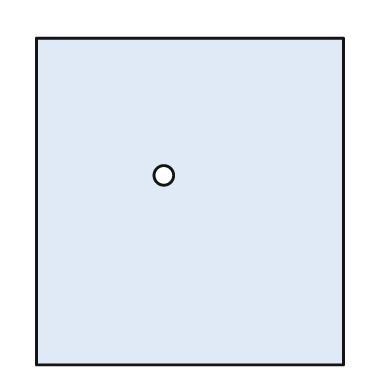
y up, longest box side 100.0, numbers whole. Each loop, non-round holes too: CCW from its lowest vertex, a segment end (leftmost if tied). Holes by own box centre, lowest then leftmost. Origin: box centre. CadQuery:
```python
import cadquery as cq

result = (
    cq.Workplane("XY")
    .moveTo(-47.0, -50.0)
    .lineTo(47.0, -50.0)
    .lineTo(47.0, 50.0)
    .lineTo(-47.0, 50.0)
    .close()
    .moveTo(-8.0, 8.0)
    .circle(3.0)
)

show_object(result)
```